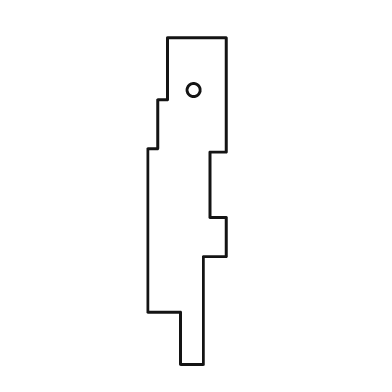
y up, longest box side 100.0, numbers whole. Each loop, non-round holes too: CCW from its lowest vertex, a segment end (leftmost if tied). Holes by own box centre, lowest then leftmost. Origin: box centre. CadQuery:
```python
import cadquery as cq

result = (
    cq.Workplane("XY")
    .moveTo(-2.0, -50.0)
    .lineTo(5.0, -50.0)
    .lineTo(5.0, -17.0)
    .lineTo(12.0, -17.0)
    .lineTo(12.0, -5.0)
    .lineTo(7.0, -5.0)
    .lineTo(7.0, 15.0)
    .lineTo(12.0, 15.0)
    .lineTo(12.0, 50.0)
    .lineTo(-6.0, 50.0)
    .lineTo(-6.0, 31.0)
    .lineTo(-9.0, 31.0)
    .lineTo(-9.0, 16.0)
    .lineTo(-12.0, 16.0)
    .lineTo(-12.0, -34.0)
    .lineTo(-2.0, -34.0)
    .close()
    .moveTo(2.0, 34.0)
    .circle(2.0)
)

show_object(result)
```